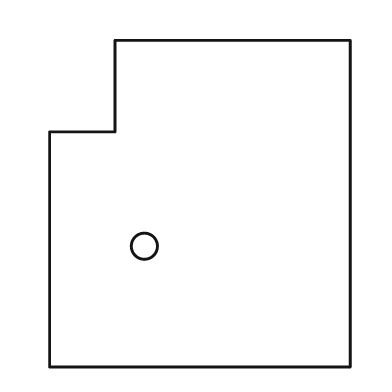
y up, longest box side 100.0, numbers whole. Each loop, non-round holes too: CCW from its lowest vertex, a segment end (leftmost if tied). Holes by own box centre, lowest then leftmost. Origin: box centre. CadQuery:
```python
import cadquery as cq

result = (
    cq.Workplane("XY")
    .moveTo(-46.0, -50.0)
    .lineTo(46.0, -50.0)
    .lineTo(46.0, 50.0)
    .lineTo(-26.0, 50.0)
    .lineTo(-26.0, 22.0)
    .lineTo(-46.0, 22.0)
    .close()
    .moveTo(-17.0, -13.0)
    .circle(4.0)
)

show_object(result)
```